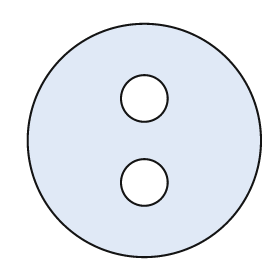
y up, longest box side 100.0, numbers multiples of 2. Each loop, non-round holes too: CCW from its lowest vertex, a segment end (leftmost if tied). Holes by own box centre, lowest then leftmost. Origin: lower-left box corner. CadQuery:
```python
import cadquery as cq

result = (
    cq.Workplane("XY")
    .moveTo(50.0, 50.0)
    .circle(50.0)
    .moveTo(50.0, 32.0)
    .circle(10.0)
    .moveTo(50.0, 68.0)
    .circle(10.0)
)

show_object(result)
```